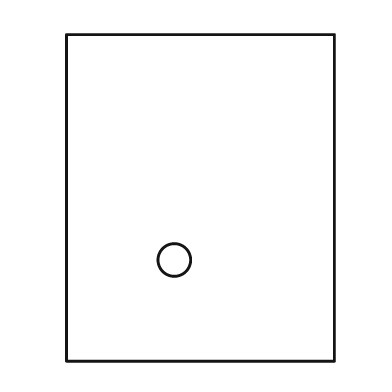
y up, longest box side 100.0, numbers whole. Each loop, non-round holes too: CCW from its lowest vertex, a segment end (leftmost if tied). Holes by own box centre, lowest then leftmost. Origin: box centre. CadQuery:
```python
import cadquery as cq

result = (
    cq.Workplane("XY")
    .moveTo(-41.0, -50.0)
    .lineTo(41.0, -50.0)
    .lineTo(41.0, 50.0)
    .lineTo(-41.0, 50.0)
    .close()
    .moveTo(-8.0, -19.0)
    .circle(5.0)
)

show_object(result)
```